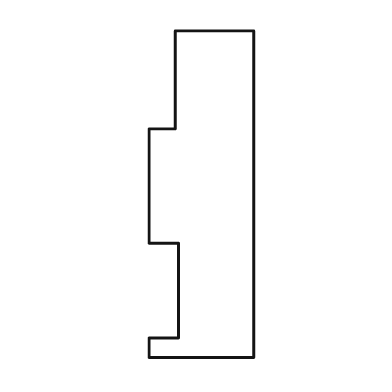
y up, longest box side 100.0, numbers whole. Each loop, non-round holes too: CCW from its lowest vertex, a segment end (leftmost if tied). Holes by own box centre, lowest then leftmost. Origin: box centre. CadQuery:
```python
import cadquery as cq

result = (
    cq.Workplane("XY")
    .moveTo(-16.0, -50.0)
    .lineTo(16.0, -50.0)
    .lineTo(16.0, 50.0)
    .lineTo(-8.0, 50.0)
    .lineTo(-8.0, 20.0)
    .lineTo(-16.0, 20.0)
    .lineTo(-16.0, -15.0)
    .lineTo(-7.0, -15.0)
    .lineTo(-7.0, -44.0)
    .lineTo(-16.0, -44.0)
    .close()
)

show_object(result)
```